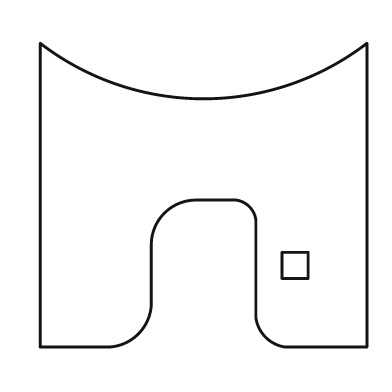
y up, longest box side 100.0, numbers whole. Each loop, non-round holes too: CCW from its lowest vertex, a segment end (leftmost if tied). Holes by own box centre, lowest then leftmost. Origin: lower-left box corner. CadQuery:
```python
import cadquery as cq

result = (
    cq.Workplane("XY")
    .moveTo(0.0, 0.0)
    .lineTo(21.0, 0.0)
    .threePointArc((30.0, 4.0), (34.0, 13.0))
    .lineTo(34.0, 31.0)
    .threePointArc((38.0, 41.0), (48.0, 45.0))
    .lineTo(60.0, 45.0)
    .threePointArc((64.0, 43.0), (66.0, 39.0))
    .lineTo(66.0, 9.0)
    .threePointArc((69.0, 3.0), (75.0, 0.0))
    .lineTo(100.0, 0.0)
    .lineTo(100.0, 93.0)
    .threePointArc((50.0, 76.0), (0.0, 93.0))
    .close()
    .moveTo(74.0, 21.0)
    .lineTo(82.0, 21.0)
    .lineTo(82.0, 29.0)
    .lineTo(74.0, 29.0)
    .close()
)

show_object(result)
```